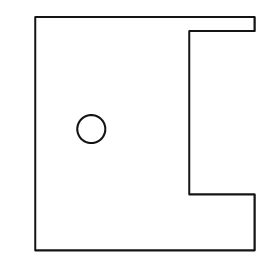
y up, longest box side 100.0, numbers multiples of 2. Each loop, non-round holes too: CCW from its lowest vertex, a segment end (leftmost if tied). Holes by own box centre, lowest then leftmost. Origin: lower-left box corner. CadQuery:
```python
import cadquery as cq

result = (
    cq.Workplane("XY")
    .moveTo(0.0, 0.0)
    .lineTo(94.0, 0.0)
    .lineTo(94.0, 24.0)
    .lineTo(66.0, 24.0)
    .lineTo(66.0, 94.0)
    .lineTo(94.0, 94.0)
    .lineTo(94.0, 100.0)
    .lineTo(0.0, 100.0)
    .close()
    .moveTo(24.0, 52.0)
    .circle(6.0)
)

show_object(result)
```